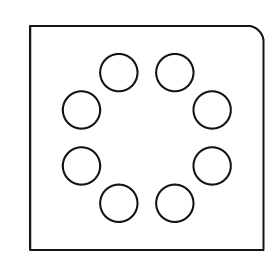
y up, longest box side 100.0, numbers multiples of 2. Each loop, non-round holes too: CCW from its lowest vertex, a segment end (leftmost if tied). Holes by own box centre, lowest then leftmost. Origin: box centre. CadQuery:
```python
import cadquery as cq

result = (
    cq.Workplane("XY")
    .moveTo(-50.0, -48.0)
    .lineTo(50.0, -48.0)
    .lineTo(50.0, 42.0)
    .threePointArc((48.0, 46.0), (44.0, 48.0))
    .lineTo(-50.0, 48.0)
    .close()
    .moveTo(-12.0, -28.0)
    .circle(8.0)
    .moveTo(12.0, -28.0)
    .circle(8.0)
    .moveTo(-28.0, -12.0)
    .circle(8.0)
    .moveTo(28.0, -12.0)
    .circle(8.0)
    .moveTo(-28.0, 12.0)
    .circle(8.0)
    .moveTo(28.0, 12.0)
    .circle(8.0)
    .moveTo(-12.0, 28.0)
    .circle(8.0)
    .moveTo(12.0, 28.0)
    .circle(8.0)
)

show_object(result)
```